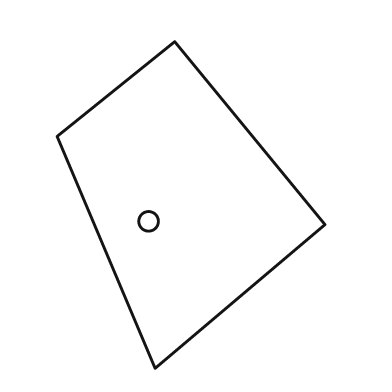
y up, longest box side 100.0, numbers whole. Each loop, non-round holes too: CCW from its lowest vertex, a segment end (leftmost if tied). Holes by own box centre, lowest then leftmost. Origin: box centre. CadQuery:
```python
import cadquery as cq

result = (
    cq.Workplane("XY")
    .moveTo(-11.0, -50.0)
    .lineTo(41.0, -6.0)
    .lineTo(-5.0, 50.0)
    .lineTo(-41.0, 21.0)
    .close()
    .moveTo(-13.0, -5.0)
    .circle(3.0)
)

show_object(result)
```